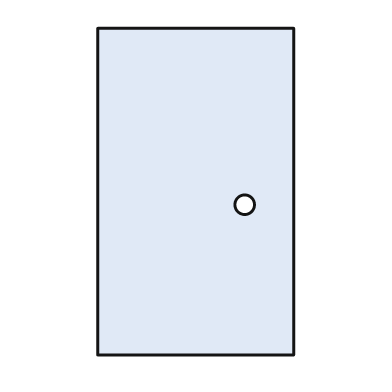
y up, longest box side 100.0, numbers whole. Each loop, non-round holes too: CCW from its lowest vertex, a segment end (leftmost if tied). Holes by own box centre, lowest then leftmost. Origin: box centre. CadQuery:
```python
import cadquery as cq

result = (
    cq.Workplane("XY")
    .moveTo(-30.0, -50.0)
    .lineTo(30.0, -50.0)
    .lineTo(30.0, 50.0)
    .lineTo(-30.0, 50.0)
    .close()
    .moveTo(15.0, -4.0)
    .circle(3.0)
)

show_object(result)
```